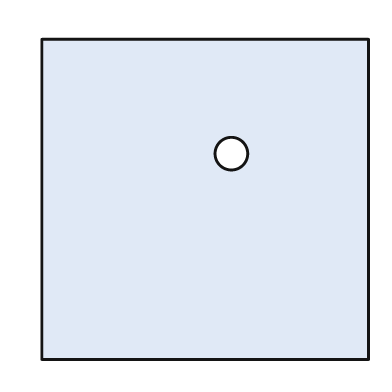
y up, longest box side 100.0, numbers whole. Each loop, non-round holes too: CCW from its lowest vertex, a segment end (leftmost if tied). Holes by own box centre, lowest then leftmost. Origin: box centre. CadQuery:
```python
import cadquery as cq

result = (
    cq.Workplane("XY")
    .moveTo(-50.0, -49.0)
    .lineTo(50.0, -49.0)
    .lineTo(50.0, 49.0)
    .lineTo(-50.0, 49.0)
    .close()
    .moveTo(8.0, 14.0)
    .circle(5.0)
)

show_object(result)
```